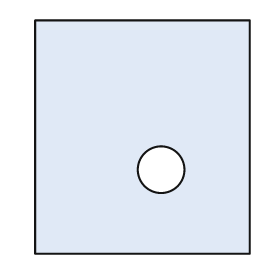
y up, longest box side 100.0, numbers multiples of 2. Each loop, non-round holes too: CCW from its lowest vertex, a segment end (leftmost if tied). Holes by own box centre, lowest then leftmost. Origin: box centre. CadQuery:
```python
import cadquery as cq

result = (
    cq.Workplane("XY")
    .moveTo(-46.0, -50.0)
    .lineTo(46.0, -50.0)
    .lineTo(46.0, 50.0)
    .lineTo(-46.0, 50.0)
    .close()
    .moveTo(8.0, -14.0)
    .circle(10.0)
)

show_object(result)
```